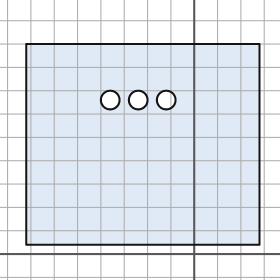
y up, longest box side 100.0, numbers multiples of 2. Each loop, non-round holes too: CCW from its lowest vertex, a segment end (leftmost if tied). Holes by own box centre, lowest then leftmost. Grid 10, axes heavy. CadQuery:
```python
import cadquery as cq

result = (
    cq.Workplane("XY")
    .moveTo(-72.0, 4.0)
    .lineTo(28.0, 4.0)
    .lineTo(28.0, 90.0)
    .lineTo(-72.0, 90.0)
    .close()
    .moveTo(-36.0, 66.0)
    .circle(4.0)
    .moveTo(-24.0, 66.0)
    .circle(4.0)
    .moveTo(-12.0, 66.0)
    .circle(4.0)
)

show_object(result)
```